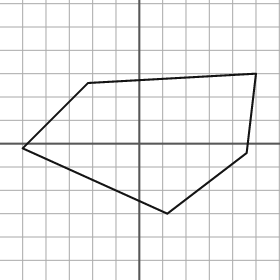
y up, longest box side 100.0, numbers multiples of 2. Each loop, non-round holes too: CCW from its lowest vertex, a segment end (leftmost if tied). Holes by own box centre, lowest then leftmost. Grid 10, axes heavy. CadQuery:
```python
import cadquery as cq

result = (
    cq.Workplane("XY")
    .moveTo(12.0, -30.0)
    .lineTo(46.0, -4.0)
    .lineTo(50.0, 30.0)
    .lineTo(-22.0, 26.0)
    .lineTo(-50.0, -2.0)
    .close()
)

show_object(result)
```